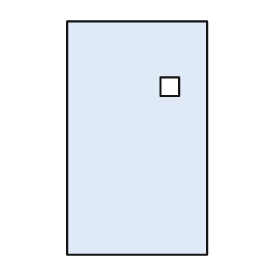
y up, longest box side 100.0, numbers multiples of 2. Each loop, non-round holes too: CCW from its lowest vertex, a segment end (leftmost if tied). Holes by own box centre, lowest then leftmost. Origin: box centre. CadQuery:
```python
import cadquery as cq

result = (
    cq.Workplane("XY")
    .moveTo(-30.0, -50.0)
    .lineTo(30.0, -50.0)
    .lineTo(30.0, 50.0)
    .lineTo(-30.0, 50.0)
    .close()
    .moveTo(10.0, 18.0)
    .lineTo(18.0, 18.0)
    .lineTo(18.0, 26.0)
    .lineTo(10.0, 26.0)
    .close()
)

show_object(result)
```